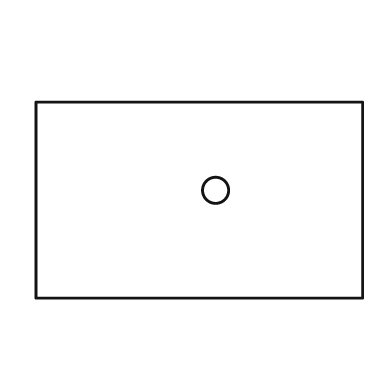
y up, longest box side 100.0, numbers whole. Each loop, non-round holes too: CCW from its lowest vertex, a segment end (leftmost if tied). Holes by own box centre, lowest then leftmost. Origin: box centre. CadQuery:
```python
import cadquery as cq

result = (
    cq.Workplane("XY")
    .moveTo(-50.0, -30.0)
    .lineTo(50.0, -30.0)
    .lineTo(50.0, 30.0)
    .lineTo(-50.0, 30.0)
    .close()
    .moveTo(5.0, 3.0)
    .circle(4.0)
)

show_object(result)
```